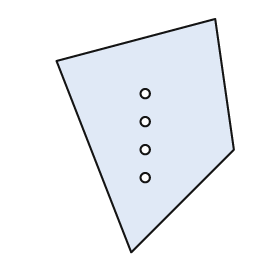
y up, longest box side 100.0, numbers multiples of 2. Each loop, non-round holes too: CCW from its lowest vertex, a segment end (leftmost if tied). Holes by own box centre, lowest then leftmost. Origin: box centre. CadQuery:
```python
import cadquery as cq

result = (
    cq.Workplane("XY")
    .moveTo(-6.0, -50.0)
    .lineTo(38.0, -6.0)
    .lineTo(30.0, 50.0)
    .lineTo(-38.0, 32.0)
    .close()
    .moveTo(0.0, -18.0)
    .circle(2.0)
    .moveTo(0.0, -6.0)
    .circle(2.0)
    .moveTo(0.0, 6.0)
    .circle(2.0)
    .moveTo(0.0, 18.0)
    .circle(2.0)
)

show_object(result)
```